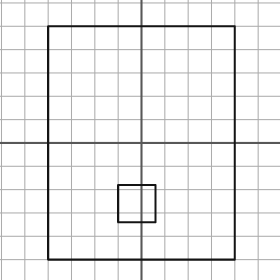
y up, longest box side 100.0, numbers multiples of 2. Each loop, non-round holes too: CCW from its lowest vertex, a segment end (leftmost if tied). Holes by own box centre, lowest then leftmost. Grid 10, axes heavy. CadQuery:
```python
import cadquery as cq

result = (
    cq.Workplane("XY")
    .moveTo(-40.0, -50.0)
    .lineTo(40.0, -50.0)
    .lineTo(40.0, 50.0)
    .lineTo(-40.0, 50.0)
    .close()
    .moveTo(-10.0, -34.0)
    .lineTo(6.0, -34.0)
    .lineTo(6.0, -18.0)
    .lineTo(-10.0, -18.0)
    .close()
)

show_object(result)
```